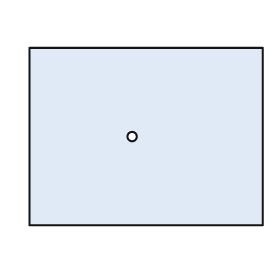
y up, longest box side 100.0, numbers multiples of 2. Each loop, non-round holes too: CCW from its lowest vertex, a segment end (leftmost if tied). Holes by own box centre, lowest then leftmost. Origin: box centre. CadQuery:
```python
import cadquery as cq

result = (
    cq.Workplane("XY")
    .moveTo(-50.0, -38.0)
    .lineTo(50.0, -38.0)
    .lineTo(50.0, 38.0)
    .lineTo(-50.0, 38.0)
    .close()
    .moveTo(-6.0, 0.0)
    .circle(2.0)
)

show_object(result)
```